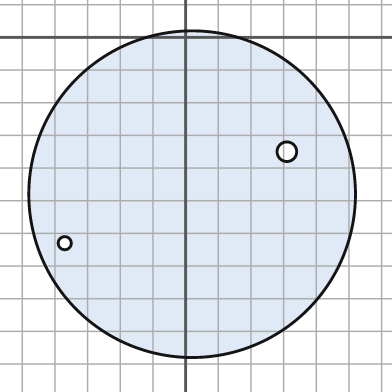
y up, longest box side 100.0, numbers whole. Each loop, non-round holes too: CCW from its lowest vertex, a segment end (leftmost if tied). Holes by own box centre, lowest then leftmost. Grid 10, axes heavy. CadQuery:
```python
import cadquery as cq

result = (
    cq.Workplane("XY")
    .moveTo(2.0, -48.0)
    .circle(50.0)
    .moveTo(-37.0, -63.0)
    .circle(2.0)
    .moveTo(31.0, -35.0)
    .circle(3.0)
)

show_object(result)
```